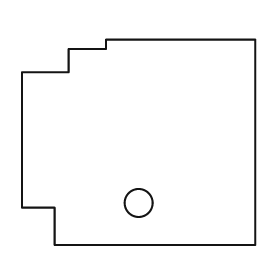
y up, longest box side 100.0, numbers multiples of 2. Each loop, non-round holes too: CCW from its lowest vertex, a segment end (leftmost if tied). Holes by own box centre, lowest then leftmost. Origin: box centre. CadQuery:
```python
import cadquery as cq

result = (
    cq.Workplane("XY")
    .moveTo(-36.0, -44.0)
    .lineTo(50.0, -44.0)
    .lineTo(50.0, 44.0)
    .lineTo(-14.0, 44.0)
    .lineTo(-14.0, 40.0)
    .lineTo(-30.0, 40.0)
    .lineTo(-30.0, 30.0)
    .lineTo(-50.0, 30.0)
    .lineTo(-50.0, -28.0)
    .lineTo(-36.0, -28.0)
    .close()
    .moveTo(0.0, -26.0)
    .circle(6.0)
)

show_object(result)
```